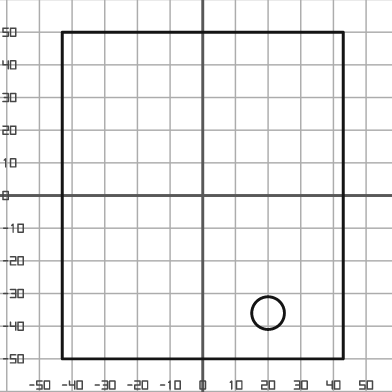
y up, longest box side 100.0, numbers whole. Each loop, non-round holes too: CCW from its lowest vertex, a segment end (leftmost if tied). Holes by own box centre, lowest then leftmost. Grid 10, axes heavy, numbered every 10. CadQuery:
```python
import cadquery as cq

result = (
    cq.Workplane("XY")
    .moveTo(-43.0, -50.0)
    .lineTo(43.0, -50.0)
    .lineTo(43.0, 50.0)
    .lineTo(-43.0, 50.0)
    .close()
    .moveTo(20.0, -36.0)
    .circle(5.0)
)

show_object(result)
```